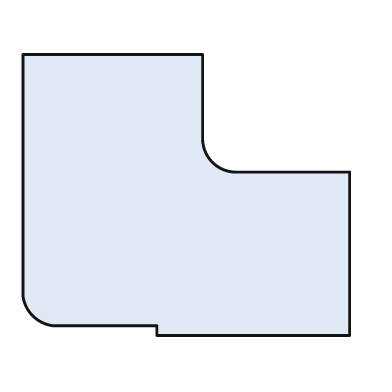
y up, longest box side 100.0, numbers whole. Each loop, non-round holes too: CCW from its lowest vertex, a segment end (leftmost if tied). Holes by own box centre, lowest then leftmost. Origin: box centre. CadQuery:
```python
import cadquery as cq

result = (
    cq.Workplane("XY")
    .moveTo(-9.0, -43.0)
    .lineTo(50.0, -43.0)
    .lineTo(50.0, 7.0)
    .lineTo(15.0, 7.0)
    .threePointArc((8.0, 10.0), (5.0, 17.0))
    .lineTo(5.0, 43.0)
    .lineTo(-50.0, 43.0)
    .lineTo(-50.0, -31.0)
    .threePointArc((-47.0, -37.0), (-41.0, -40.0))
    .lineTo(-9.0, -40.0)
    .close()
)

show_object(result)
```